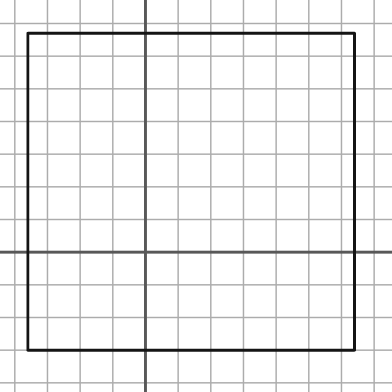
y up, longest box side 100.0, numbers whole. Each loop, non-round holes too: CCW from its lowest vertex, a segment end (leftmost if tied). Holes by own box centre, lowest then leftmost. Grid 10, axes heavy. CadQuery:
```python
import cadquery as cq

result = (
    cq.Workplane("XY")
    .moveTo(-36.0, -30.0)
    .lineTo(64.0, -30.0)
    .lineTo(64.0, 67.0)
    .lineTo(-36.0, 67.0)
    .close()
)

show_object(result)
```